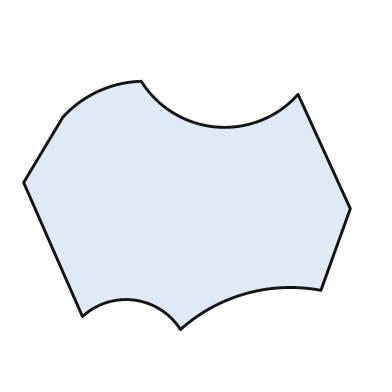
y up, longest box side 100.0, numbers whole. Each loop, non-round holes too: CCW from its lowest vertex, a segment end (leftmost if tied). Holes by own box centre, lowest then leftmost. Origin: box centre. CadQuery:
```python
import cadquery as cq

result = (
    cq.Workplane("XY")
    .moveTo(-2.0, -38.0)
    .threePointArc((18.0, -27.0), (41.0, -26.0))
    .lineTo(50.0, -1.0)
    .lineTo(34.0, 34.0)
    .threePointArc((9.0, 24.0), (-14.0, 38.0))
    .threePointArc((-27.0, 35.0), (-38.0, 27.0))
    .lineTo(-50.0, 7.0)
    .lineTo(-32.0, -34.0)
    .threePointArc((-16.0, -29.0), (-2.0, -38.0))
    .close()
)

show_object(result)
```